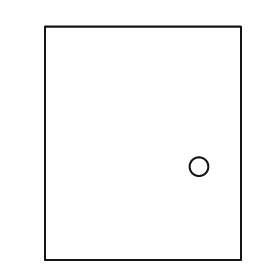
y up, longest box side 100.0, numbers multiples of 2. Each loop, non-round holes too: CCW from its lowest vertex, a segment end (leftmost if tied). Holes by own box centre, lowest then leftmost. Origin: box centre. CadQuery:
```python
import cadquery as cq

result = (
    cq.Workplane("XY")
    .moveTo(-42.0, -50.0)
    .lineTo(42.0, -50.0)
    .lineTo(42.0, 50.0)
    .lineTo(-42.0, 50.0)
    .close()
    .moveTo(24.0, -10.0)
    .circle(4.0)
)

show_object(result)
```